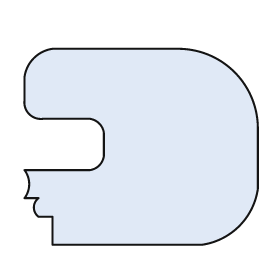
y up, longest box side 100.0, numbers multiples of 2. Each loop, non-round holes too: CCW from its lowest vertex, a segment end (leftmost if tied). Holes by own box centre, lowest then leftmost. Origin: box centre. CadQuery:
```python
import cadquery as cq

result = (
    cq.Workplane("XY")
    .moveTo(-38.0, -42.0)
    .lineTo(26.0, -42.0)
    .threePointArc((42.0, -34.0), (50.0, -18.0))
    .lineTo(50.0, 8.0)
    .threePointArc((40.0, 32.0), (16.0, 42.0))
    .lineTo(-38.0, 42.0)
    .threePointArc((-46.0, 38.0), (-50.0, 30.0))
    .lineTo(-50.0, 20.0)
    .threePointArc((-48.0, 14.0), (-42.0, 12.0))
    .lineTo(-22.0, 12.0)
    .threePointArc((-18.0, 10.0), (-16.0, 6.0))
    .lineTo(-16.0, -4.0)
    .threePointArc((-18.0, -8.0), (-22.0, -10.0))
    .lineTo(-50.0, -10.0)
    .threePointArc((-48.0, -16.0), (-50.0, -22.0))
    .lineTo(-44.0, -22.0)
    .threePointArc((-46.0, -26.0), (-44.0, -30.0))
    .lineTo(-38.0, -30.0)
    .close()
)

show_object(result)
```